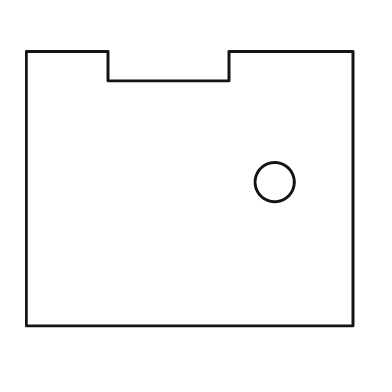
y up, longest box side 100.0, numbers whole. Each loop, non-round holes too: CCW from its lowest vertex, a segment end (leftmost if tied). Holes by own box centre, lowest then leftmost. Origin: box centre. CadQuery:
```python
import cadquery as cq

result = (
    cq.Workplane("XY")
    .moveTo(-50.0, -42.0)
    .lineTo(50.0, -42.0)
    .lineTo(50.0, 42.0)
    .lineTo(12.0, 42.0)
    .lineTo(12.0, 33.0)
    .lineTo(-25.0, 33.0)
    .lineTo(-25.0, 42.0)
    .lineTo(-50.0, 42.0)
    .close()
    .moveTo(26.0, 2.0)
    .circle(6.0)
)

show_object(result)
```